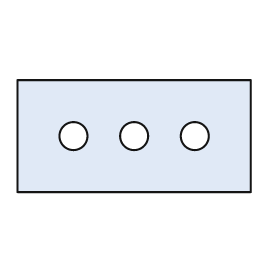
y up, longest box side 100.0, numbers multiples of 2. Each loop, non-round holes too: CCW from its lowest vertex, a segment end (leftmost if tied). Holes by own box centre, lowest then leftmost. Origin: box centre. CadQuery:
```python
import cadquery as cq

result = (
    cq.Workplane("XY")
    .moveTo(-50.0, -24.0)
    .lineTo(50.0, -24.0)
    .lineTo(50.0, 24.0)
    .lineTo(-50.0, 24.0)
    .close()
    .moveTo(-26.0, 0.0)
    .circle(6.0)
    .moveTo(0.0, 0.0)
    .circle(6.0)
    .moveTo(26.0, 0.0)
    .circle(6.0)
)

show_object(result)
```